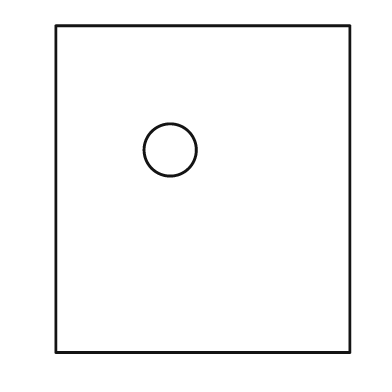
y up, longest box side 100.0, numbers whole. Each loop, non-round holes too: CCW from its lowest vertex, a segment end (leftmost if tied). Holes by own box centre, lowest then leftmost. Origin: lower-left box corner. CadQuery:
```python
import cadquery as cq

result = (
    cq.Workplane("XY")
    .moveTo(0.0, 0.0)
    .lineTo(90.0, 0.0)
    .lineTo(90.0, 100.0)
    .lineTo(0.0, 100.0)
    .close()
    .moveTo(35.0, 62.0)
    .circle(8.0)
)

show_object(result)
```